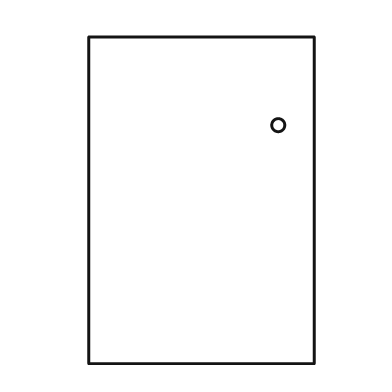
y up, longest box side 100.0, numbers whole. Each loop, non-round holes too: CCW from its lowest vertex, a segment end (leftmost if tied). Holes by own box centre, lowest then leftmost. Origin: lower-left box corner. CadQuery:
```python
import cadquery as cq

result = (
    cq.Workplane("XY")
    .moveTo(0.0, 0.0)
    .lineTo(69.0, 0.0)
    .lineTo(69.0, 100.0)
    .lineTo(0.0, 100.0)
    .close()
    .moveTo(58.0, 73.0)
    .circle(2.0)
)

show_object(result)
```